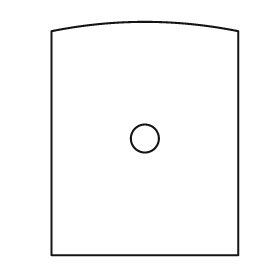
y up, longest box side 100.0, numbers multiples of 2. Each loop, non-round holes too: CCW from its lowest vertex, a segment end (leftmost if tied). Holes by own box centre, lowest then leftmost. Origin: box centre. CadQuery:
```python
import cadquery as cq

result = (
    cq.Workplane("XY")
    .moveTo(-40.0, -50.0)
    .lineTo(40.0, -50.0)
    .lineTo(40.0, 46.0)
    .threePointArc((0.0, 50.0), (-40.0, 46.0))
    .close()
    .moveTo(0.0, 0.0)
    .circle(6.0)
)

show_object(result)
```